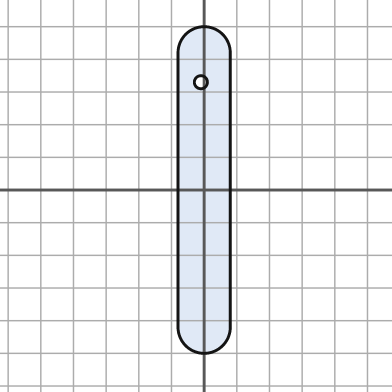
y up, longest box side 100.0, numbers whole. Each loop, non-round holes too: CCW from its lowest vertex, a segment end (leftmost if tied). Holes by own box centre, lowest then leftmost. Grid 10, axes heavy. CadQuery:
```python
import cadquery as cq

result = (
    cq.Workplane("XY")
    .moveTo(-8.0, -42.0)
    .threePointArc((0.0, -50.0), (8.0, -42.0))
    .lineTo(8.0, 42.0)
    .threePointArc((0.0, 50.0), (-8.0, 42.0))
    .close()
    .moveTo(-1.0, 33.0)
    .circle(2.0)
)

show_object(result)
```